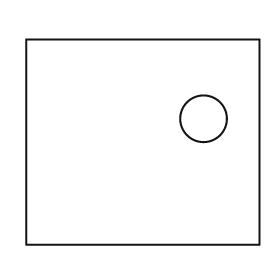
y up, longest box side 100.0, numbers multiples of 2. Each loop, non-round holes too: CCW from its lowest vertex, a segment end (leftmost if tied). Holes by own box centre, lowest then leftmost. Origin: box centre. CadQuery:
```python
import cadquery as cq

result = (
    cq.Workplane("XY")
    .moveTo(-50.0, -44.0)
    .lineTo(50.0, -44.0)
    .lineTo(50.0, 44.0)
    .lineTo(-50.0, 44.0)
    .close()
    .moveTo(26.0, 10.0)
    .circle(10.0)
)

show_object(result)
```